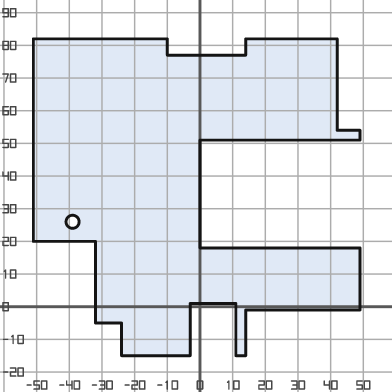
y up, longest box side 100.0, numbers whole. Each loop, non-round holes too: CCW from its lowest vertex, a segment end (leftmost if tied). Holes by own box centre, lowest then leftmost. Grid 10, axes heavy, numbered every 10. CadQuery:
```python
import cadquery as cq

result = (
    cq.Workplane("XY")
    .moveTo(-24.0, -15.0)
    .lineTo(-3.0, -15.0)
    .lineTo(-3.0, 1.0)
    .lineTo(11.0, 1.0)
    .lineTo(11.0, -15.0)
    .lineTo(14.0, -15.0)
    .lineTo(14.0, -1.0)
    .lineTo(49.0, -1.0)
    .lineTo(49.0, 18.0)
    .lineTo(0.0, 18.0)
    .lineTo(0.0, 51.0)
    .lineTo(49.0, 51.0)
    .lineTo(49.0, 54.0)
    .lineTo(42.0, 54.0)
    .lineTo(42.0, 82.0)
    .lineTo(14.0, 82.0)
    .lineTo(14.0, 77.0)
    .lineTo(-10.0, 77.0)
    .lineTo(-10.0, 82.0)
    .lineTo(-51.0, 82.0)
    .lineTo(-51.0, 20.0)
    .lineTo(-32.0, 20.0)
    .lineTo(-32.0, -5.0)
    .lineTo(-24.0, -5.0)
    .close()
    .moveTo(-39.0, 26.0)
    .circle(2.0)
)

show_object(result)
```